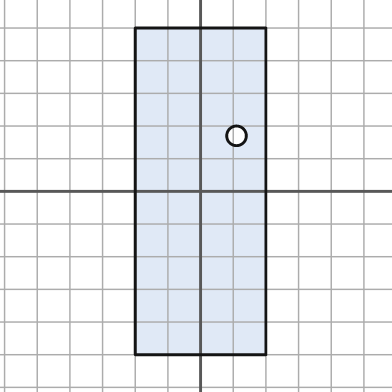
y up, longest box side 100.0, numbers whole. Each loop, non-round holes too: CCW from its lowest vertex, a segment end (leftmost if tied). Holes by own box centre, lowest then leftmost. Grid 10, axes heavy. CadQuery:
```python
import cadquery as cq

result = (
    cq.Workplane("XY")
    .moveTo(-20.0, -50.0)
    .lineTo(20.0, -50.0)
    .lineTo(20.0, 50.0)
    .lineTo(-20.0, 50.0)
    .close()
    .moveTo(11.0, 17.0)
    .circle(3.0)
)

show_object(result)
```